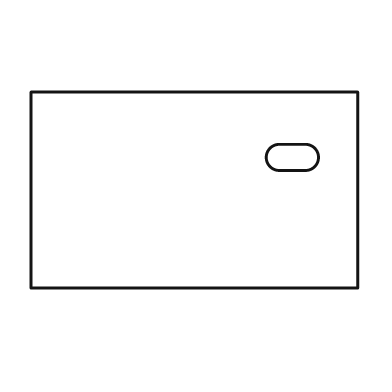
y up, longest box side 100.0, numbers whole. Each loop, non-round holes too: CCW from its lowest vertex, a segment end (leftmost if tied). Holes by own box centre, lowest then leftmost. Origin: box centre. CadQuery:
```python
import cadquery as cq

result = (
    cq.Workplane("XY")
    .moveTo(-50.0, -30.0)
    .lineTo(50.0, -30.0)
    .lineTo(50.0, 30.0)
    .lineTo(-50.0, 30.0)
    .close()
    .moveTo(26.0, 6.0)
    .lineTo(34.0, 6.0)
    .threePointArc((38.0, 10.0), (34.0, 14.0))
    .lineTo(26.0, 14.0)
    .threePointArc((22.0, 10.0), (26.0, 6.0))
    .close()
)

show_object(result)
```